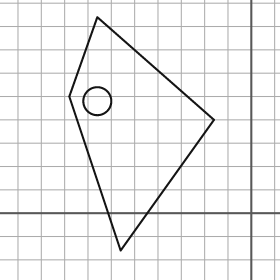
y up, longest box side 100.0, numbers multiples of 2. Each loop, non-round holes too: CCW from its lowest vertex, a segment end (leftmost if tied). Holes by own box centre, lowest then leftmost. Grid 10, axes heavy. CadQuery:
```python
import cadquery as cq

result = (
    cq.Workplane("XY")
    .moveTo(-56.0, -16.0)
    .lineTo(-16.0, 40.0)
    .lineTo(-66.0, 84.0)
    .lineTo(-78.0, 50.0)
    .close()
    .moveTo(-66.0, 48.0)
    .circle(6.0)
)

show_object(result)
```